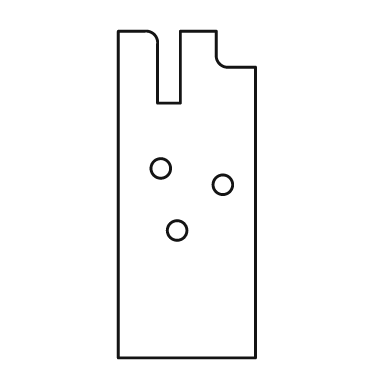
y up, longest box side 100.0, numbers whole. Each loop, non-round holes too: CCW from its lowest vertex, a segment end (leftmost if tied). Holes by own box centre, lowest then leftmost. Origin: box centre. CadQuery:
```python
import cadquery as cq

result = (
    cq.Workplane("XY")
    .moveTo(-21.0, -50.0)
    .lineTo(21.0, -50.0)
    .lineTo(21.0, 39.0)
    .lineTo(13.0, 39.0)
    .threePointArc((10.0, 40.0), (9.0, 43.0))
    .lineTo(9.0, 50.0)
    .lineTo(-2.0, 50.0)
    .lineTo(-2.0, 28.0)
    .lineTo(-9.0, 28.0)
    .lineTo(-9.0, 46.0)
    .threePointArc((-10.0, 49.0), (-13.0, 50.0))
    .lineTo(-21.0, 50.0)
    .close()
    .moveTo(-3.0, -11.0)
    .circle(3.0)
    .moveTo(11.0, 3.0)
    .circle(3.0)
    .moveTo(-8.0, 8.0)
    .circle(3.0)
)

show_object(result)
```